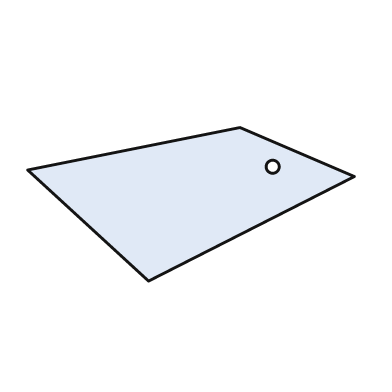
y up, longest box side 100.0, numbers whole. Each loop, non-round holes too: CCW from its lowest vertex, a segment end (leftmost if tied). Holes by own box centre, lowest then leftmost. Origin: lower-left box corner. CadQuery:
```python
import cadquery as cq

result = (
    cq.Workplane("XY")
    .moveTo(37.0, 0.0)
    .lineTo(100.0, 32.0)
    .lineTo(65.0, 47.0)
    .lineTo(0.0, 34.0)
    .close()
    .moveTo(75.0, 35.0)
    .circle(2.0)
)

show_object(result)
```